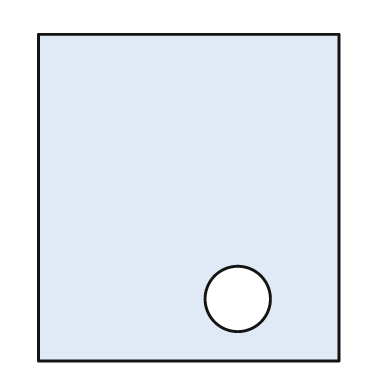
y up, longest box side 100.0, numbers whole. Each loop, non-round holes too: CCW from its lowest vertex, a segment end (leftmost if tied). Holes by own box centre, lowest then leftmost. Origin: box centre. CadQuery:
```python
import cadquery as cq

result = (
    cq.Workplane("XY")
    .moveTo(-46.0, -50.0)
    .lineTo(46.0, -50.0)
    .lineTo(46.0, 50.0)
    .lineTo(-46.0, 50.0)
    .close()
    .moveTo(15.0, -31.0)
    .circle(10.0)
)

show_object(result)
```